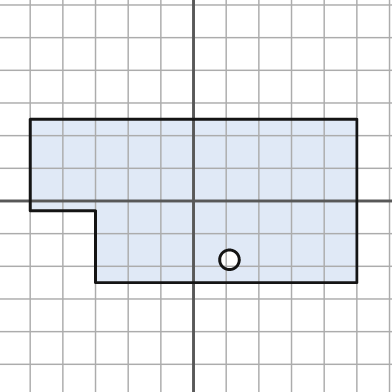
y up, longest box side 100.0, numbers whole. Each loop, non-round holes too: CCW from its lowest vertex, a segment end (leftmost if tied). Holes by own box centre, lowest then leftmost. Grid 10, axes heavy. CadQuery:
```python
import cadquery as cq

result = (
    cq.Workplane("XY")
    .moveTo(-30.0, -25.0)
    .lineTo(50.0, -25.0)
    .lineTo(50.0, 25.0)
    .lineTo(-50.0, 25.0)
    .lineTo(-50.0, -3.0)
    .lineTo(-30.0, -3.0)
    .close()
    .moveTo(11.0, -18.0)
    .circle(3.0)
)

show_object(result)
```